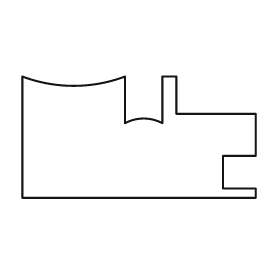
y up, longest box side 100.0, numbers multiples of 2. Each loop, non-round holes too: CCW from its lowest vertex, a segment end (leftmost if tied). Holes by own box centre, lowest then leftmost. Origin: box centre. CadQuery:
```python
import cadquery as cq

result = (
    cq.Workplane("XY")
    .moveTo(-50.0, -26.0)
    .lineTo(50.0, -26.0)
    .lineTo(50.0, -22.0)
    .lineTo(36.0, -22.0)
    .lineTo(36.0, -8.0)
    .lineTo(50.0, -8.0)
    .lineTo(50.0, 10.0)
    .lineTo(16.0, 10.0)
    .lineTo(16.0, 26.0)
    .lineTo(10.0, 26.0)
    .lineTo(10.0, 6.0)
    .threePointArc((2.0, 8.0), (-6.0, 6.0))
    .lineTo(-6.0, 26.0)
    .threePointArc((-28.0, 22.0), (-50.0, 26.0))
    .close()
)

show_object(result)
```